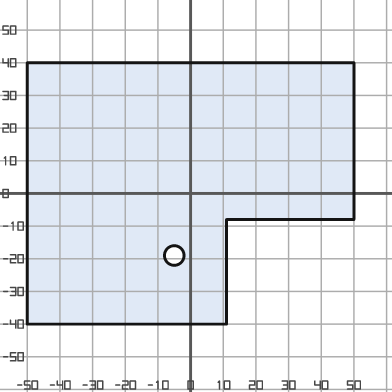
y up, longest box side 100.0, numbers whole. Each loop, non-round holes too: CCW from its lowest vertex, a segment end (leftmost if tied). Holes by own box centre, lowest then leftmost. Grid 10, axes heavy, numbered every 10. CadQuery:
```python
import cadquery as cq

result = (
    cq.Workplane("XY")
    .moveTo(-50.0, -40.0)
    .lineTo(11.0, -40.0)
    .lineTo(11.0, -8.0)
    .lineTo(50.0, -8.0)
    .lineTo(50.0, 40.0)
    .lineTo(-50.0, 40.0)
    .close()
    .moveTo(-5.0, -19.0)
    .circle(3.0)
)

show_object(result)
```